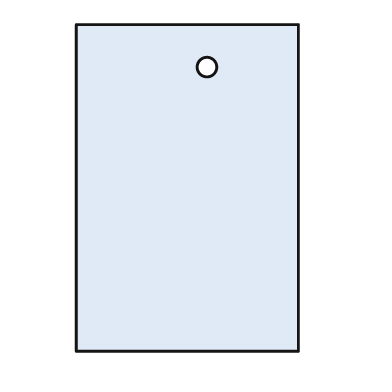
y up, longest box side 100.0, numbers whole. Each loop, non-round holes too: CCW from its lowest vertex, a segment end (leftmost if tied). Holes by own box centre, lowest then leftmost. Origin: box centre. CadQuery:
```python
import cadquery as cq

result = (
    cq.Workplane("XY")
    .moveTo(-34.0, -50.0)
    .lineTo(34.0, -50.0)
    .lineTo(34.0, 50.0)
    .lineTo(-34.0, 50.0)
    .close()
    .moveTo(6.0, 37.0)
    .circle(3.0)
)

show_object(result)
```